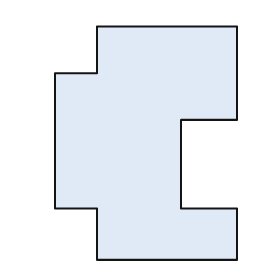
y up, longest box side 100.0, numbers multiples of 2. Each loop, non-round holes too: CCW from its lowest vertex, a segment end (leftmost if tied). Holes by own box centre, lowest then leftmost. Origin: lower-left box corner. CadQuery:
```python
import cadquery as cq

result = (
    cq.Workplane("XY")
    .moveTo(18.0, 0.0)
    .lineTo(78.0, 0.0)
    .lineTo(78.0, 22.0)
    .lineTo(54.0, 22.0)
    .lineTo(54.0, 60.0)
    .lineTo(78.0, 60.0)
    .lineTo(78.0, 100.0)
    .lineTo(18.0, 100.0)
    .lineTo(18.0, 80.0)
    .lineTo(0.0, 80.0)
    .lineTo(0.0, 22.0)
    .lineTo(18.0, 22.0)
    .close()
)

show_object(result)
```